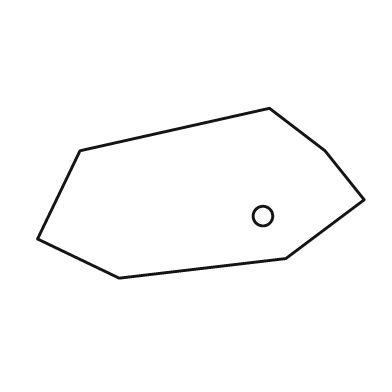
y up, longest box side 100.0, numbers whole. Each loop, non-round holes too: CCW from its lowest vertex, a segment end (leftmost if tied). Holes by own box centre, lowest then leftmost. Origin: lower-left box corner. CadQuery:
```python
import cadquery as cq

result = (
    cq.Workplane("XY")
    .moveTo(25.0, 0.0)
    .lineTo(76.0, 6.0)
    .lineTo(100.0, 24.0)
    .lineTo(88.0, 39.0)
    .lineTo(71.0, 52.0)
    .lineTo(13.0, 39.0)
    .lineTo(0.0, 12.0)
    .close()
    .moveTo(69.0, 19.0)
    .circle(3.0)
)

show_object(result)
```